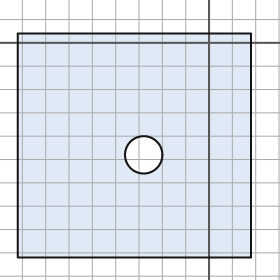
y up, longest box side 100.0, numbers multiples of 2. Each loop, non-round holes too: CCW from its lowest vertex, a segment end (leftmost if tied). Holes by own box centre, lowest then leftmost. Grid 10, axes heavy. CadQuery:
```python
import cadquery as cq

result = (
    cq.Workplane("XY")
    .moveTo(-82.0, -92.0)
    .lineTo(18.0, -92.0)
    .lineTo(18.0, 4.0)
    .lineTo(-82.0, 4.0)
    .close()
    .moveTo(-28.0, -48.0)
    .circle(8.0)
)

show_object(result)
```